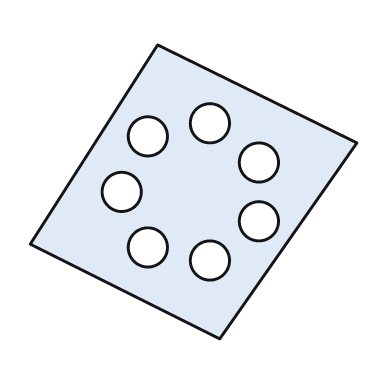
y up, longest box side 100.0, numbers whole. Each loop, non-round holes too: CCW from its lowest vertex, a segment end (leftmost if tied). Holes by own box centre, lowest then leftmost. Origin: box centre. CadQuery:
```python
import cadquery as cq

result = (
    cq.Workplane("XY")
    .moveTo(8.0, -45.0)
    .lineTo(50.0, 15.0)
    .lineTo(-11.0, 45.0)
    .lineTo(-50.0, -16.0)
    .close()
    .moveTo(5.0, -21.0)
    .circle(6.0)
    .moveTo(-14.0, -17.0)
    .circle(6.0)
    .moveTo(20.0, -9.0)
    .circle(6.0)
    .moveTo(-22.0, 0.0)
    .circle(6.0)
    .moveTo(20.0, 9.0)
    .circle(6.0)
    .moveTo(-14.0, 17.0)
    .circle(6.0)
    .moveTo(5.0, 21.0)
    .circle(6.0)
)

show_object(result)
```